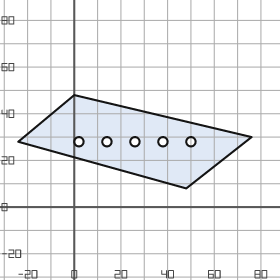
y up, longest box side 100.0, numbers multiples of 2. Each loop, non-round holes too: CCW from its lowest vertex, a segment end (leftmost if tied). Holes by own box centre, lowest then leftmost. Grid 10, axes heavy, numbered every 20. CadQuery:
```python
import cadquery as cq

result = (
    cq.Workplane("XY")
    .moveTo(48.0, 8.0)
    .lineTo(76.0, 30.0)
    .lineTo(0.0, 48.0)
    .lineTo(-24.0, 28.0)
    .close()
    .moveTo(2.0, 28.0)
    .circle(2.0)
    .moveTo(14.0, 28.0)
    .circle(2.0)
    .moveTo(26.0, 28.0)
    .circle(2.0)
    .moveTo(38.0, 28.0)
    .circle(2.0)
    .moveTo(50.0, 28.0)
    .circle(2.0)
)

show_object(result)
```